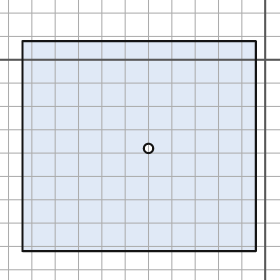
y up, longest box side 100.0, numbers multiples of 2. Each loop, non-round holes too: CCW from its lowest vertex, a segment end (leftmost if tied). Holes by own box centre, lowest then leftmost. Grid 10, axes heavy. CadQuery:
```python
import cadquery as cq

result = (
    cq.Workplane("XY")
    .moveTo(-104.0, -82.0)
    .lineTo(-4.0, -82.0)
    .lineTo(-4.0, 8.0)
    .lineTo(-104.0, 8.0)
    .close()
    .moveTo(-50.0, -38.0)
    .circle(2.0)
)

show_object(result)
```